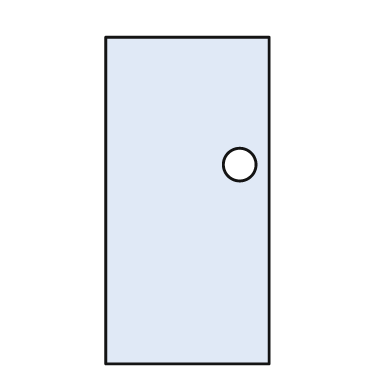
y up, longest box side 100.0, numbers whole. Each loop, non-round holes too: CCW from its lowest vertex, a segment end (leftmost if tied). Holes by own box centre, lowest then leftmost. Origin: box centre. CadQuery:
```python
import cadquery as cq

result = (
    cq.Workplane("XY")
    .moveTo(-25.0, -50.0)
    .lineTo(25.0, -50.0)
    .lineTo(25.0, 50.0)
    .lineTo(-25.0, 50.0)
    .close()
    .moveTo(16.0, 11.0)
    .circle(5.0)
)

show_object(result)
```